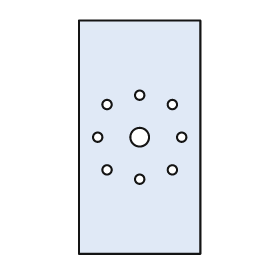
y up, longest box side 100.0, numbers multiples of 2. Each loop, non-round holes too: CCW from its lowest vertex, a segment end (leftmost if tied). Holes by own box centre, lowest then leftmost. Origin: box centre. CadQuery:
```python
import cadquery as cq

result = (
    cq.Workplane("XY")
    .moveTo(-26.0, -50.0)
    .lineTo(26.0, -50.0)
    .lineTo(26.0, 50.0)
    .lineTo(-26.0, 50.0)
    .close()
    .moveTo(0.0, -18.0)
    .circle(2.0)
    .moveTo(-14.0, -14.0)
    .circle(2.0)
    .moveTo(14.0, -14.0)
    .circle(2.0)
    .moveTo(-18.0, 0.0)
    .circle(2.0)
    .moveTo(0.0, 0.0)
    .circle(4.0)
    .moveTo(18.0, 0.0)
    .circle(2.0)
    .moveTo(-14.0, 14.0)
    .circle(2.0)
    .moveTo(14.0, 14.0)
    .circle(2.0)
    .moveTo(0.0, 18.0)
    .circle(2.0)
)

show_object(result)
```